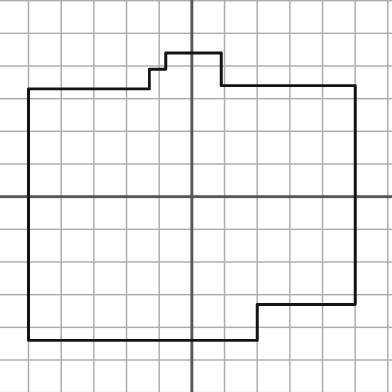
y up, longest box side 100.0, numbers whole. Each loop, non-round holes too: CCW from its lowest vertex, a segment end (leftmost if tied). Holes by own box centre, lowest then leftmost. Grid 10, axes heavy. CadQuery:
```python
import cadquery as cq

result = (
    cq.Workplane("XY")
    .moveTo(-50.0, -44.0)
    .lineTo(20.0, -44.0)
    .lineTo(20.0, -33.0)
    .lineTo(50.0, -33.0)
    .lineTo(50.0, 34.0)
    .lineTo(9.0, 34.0)
    .lineTo(9.0, 44.0)
    .lineTo(-8.0, 44.0)
    .lineTo(-8.0, 39.0)
    .lineTo(-13.0, 39.0)
    .lineTo(-13.0, 33.0)
    .lineTo(-50.0, 33.0)
    .close()
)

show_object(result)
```